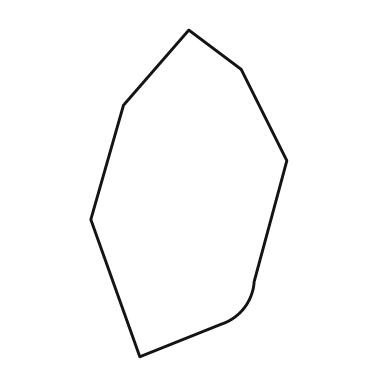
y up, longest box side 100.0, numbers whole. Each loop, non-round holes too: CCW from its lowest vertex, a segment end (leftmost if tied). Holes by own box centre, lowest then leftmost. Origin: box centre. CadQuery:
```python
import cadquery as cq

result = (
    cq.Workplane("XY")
    .moveTo(-15.0, -50.0)
    .lineTo(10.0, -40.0)
    .threePointArc((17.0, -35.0), (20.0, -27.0))
    .lineTo(30.0, 10.0)
    .lineTo(16.0, 38.0)
    .lineTo(0.0, 50.0)
    .lineTo(-20.0, 27.0)
    .lineTo(-30.0, -8.0)
    .close()
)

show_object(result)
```